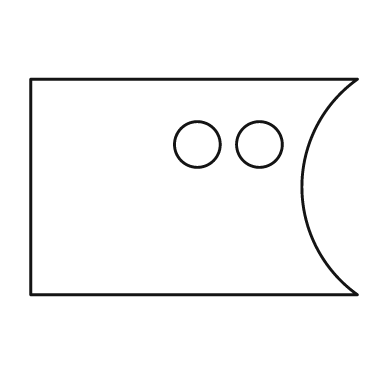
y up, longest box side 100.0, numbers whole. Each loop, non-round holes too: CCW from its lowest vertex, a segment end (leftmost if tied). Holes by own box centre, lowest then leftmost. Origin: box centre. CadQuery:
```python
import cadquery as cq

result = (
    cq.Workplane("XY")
    .moveTo(-50.0, -33.0)
    .lineTo(50.0, -33.0)
    .threePointArc((33.0, 0.0), (50.0, 33.0))
    .lineTo(-50.0, 33.0)
    .close()
    .moveTo(1.0, 13.0)
    .circle(7.0)
    .moveTo(20.0, 13.0)
    .circle(7.0)
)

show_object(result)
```